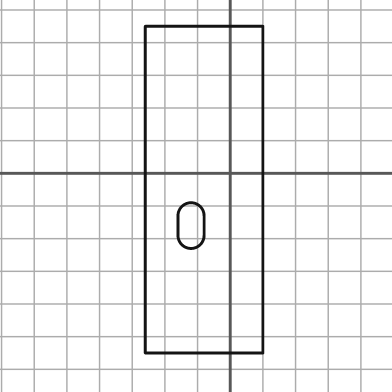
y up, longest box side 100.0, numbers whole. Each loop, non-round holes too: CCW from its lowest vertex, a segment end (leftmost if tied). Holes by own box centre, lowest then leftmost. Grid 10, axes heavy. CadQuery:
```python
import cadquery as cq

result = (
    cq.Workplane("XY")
    .moveTo(-26.0, -55.0)
    .lineTo(10.0, -55.0)
    .lineTo(10.0, 45.0)
    .lineTo(-26.0, 45.0)
    .close()
    .moveTo(-16.0, -19.0)
    .threePointArc((-12.0, -23.0), (-8.0, -19.0))
    .lineTo(-8.0, -13.0)
    .threePointArc((-12.0, -9.0), (-16.0, -13.0))
    .close()
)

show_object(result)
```